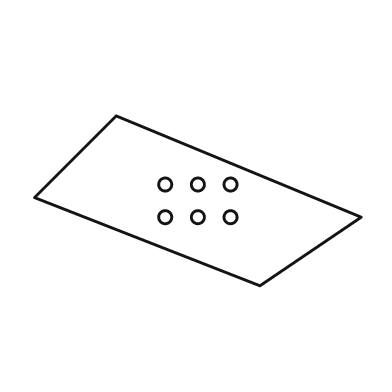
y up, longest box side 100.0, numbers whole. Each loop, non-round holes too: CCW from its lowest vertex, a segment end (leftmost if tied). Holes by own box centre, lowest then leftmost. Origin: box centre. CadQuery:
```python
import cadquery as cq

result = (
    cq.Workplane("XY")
    .moveTo(19.0, -26.0)
    .lineTo(50.0, -5.0)
    .lineTo(-25.0, 26.0)
    .lineTo(-50.0, 1.0)
    .close()
    .moveTo(-10.0, -5.0)
    .circle(2.0)
    .moveTo(0.0, -5.0)
    .circle(2.0)
    .moveTo(10.0, -5.0)
    .circle(2.0)
    .moveTo(-10.0, 5.0)
    .circle(2.0)
    .moveTo(0.0, 5.0)
    .circle(2.0)
    .moveTo(10.0, 5.0)
    .circle(2.0)
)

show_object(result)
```